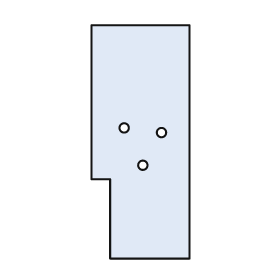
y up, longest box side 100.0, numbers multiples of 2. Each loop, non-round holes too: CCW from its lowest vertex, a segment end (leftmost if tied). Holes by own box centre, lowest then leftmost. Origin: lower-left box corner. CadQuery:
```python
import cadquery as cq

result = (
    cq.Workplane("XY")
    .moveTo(8.0, 0.0)
    .lineTo(42.0, 0.0)
    .lineTo(42.0, 100.0)
    .lineTo(0.0, 100.0)
    .lineTo(0.0, 34.0)
    .lineTo(8.0, 34.0)
    .close()
    .moveTo(22.0, 40.0)
    .circle(2.0)
    .moveTo(30.0, 54.0)
    .circle(2.0)
    .moveTo(14.0, 56.0)
    .circle(2.0)
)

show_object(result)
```